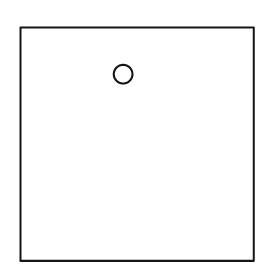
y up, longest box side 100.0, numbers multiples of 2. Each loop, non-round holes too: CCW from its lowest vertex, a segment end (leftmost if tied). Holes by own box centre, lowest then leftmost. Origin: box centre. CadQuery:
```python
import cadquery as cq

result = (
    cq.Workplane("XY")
    .moveTo(-50.0, -50.0)
    .lineTo(50.0, -50.0)
    .lineTo(50.0, 50.0)
    .lineTo(-50.0, 50.0)
    .close()
    .moveTo(-6.0, 30.0)
    .circle(4.0)
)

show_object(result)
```